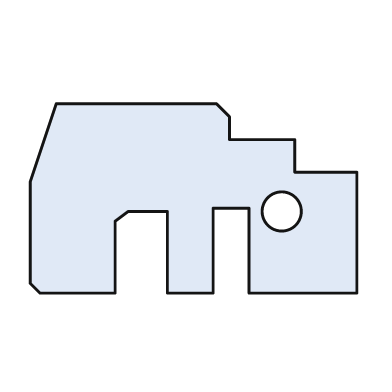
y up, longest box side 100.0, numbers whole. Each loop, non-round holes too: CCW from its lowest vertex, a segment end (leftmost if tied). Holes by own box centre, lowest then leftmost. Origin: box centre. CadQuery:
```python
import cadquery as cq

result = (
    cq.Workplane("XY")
    .moveTo(-47.0, -29.0)
    .lineTo(-24.0, -29.0)
    .lineTo(-24.0, -7.0)
    .lineTo(-20.0, -4.0)
    .lineTo(-8.0, -4.0)
    .lineTo(-8.0, -29.0)
    .lineTo(6.0, -29.0)
    .lineTo(6.0, -3.0)
    .lineTo(17.0, -3.0)
    .lineTo(17.0, -29.0)
    .lineTo(50.0, -29.0)
    .lineTo(50.0, 8.0)
    .lineTo(31.0, 8.0)
    .lineTo(31.0, 18.0)
    .lineTo(11.0, 18.0)
    .lineTo(11.0, 25.0)
    .lineTo(7.0, 29.0)
    .lineTo(-42.0, 29.0)
    .lineTo(-50.0, 5.0)
    .lineTo(-50.0, -26.0)
    .close()
    .moveTo(27.0, -4.0)
    .circle(6.0)
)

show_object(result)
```